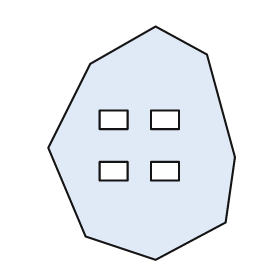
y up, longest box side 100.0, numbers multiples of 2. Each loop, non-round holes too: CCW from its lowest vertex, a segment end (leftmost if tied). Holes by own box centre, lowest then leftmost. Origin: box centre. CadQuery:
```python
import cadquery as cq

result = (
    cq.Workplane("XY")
    .moveTo(6.0, -50.0)
    .lineTo(36.0, -34.0)
    .lineTo(40.0, -6.0)
    .lineTo(28.0, 38.0)
    .lineTo(6.0, 50.0)
    .lineTo(-22.0, 34.0)
    .lineTo(-40.0, -2.0)
    .lineTo(-24.0, -40.0)
    .close()
    .moveTo(-18.0, -16.0)
    .lineTo(-6.0, -16.0)
    .lineTo(-6.0, -8.0)
    .lineTo(-18.0, -8.0)
    .close()
    .moveTo(4.0, -16.0)
    .lineTo(16.0, -16.0)
    .lineTo(16.0, -8.0)
    .lineTo(4.0, -8.0)
    .close()
    .moveTo(-18.0, 6.0)
    .lineTo(-6.0, 6.0)
    .lineTo(-6.0, 14.0)
    .lineTo(-18.0, 14.0)
    .close()
    .moveTo(4.0, 6.0)
    .lineTo(16.0, 6.0)
    .lineTo(16.0, 14.0)
    .lineTo(4.0, 14.0)
    .close()
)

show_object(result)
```